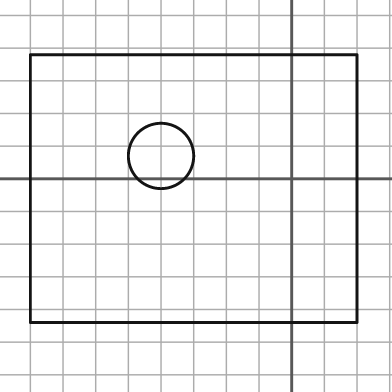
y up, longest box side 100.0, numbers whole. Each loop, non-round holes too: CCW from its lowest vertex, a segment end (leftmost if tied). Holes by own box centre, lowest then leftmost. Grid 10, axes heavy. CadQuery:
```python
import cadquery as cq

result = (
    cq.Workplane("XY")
    .moveTo(-80.0, -44.0)
    .lineTo(20.0, -44.0)
    .lineTo(20.0, 38.0)
    .lineTo(-80.0, 38.0)
    .close()
    .moveTo(-40.0, 7.0)
    .circle(10.0)
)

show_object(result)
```